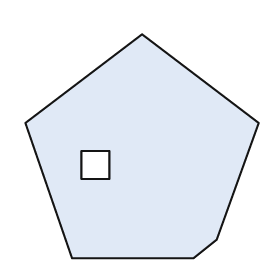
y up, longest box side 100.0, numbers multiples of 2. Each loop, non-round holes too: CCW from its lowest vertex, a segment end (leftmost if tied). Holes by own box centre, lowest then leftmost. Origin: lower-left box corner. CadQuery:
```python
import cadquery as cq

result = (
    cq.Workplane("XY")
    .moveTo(20.0, 0.0)
    .lineTo(72.0, 0.0)
    .lineTo(82.0, 8.0)
    .lineTo(100.0, 58.0)
    .lineTo(50.0, 96.0)
    .lineTo(0.0, 58.0)
    .close()
    .moveTo(24.0, 34.0)
    .lineTo(36.0, 34.0)
    .lineTo(36.0, 46.0)
    .lineTo(24.0, 46.0)
    .close()
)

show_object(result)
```